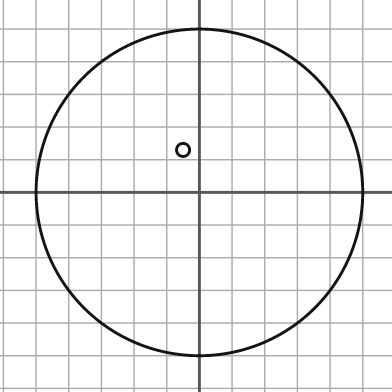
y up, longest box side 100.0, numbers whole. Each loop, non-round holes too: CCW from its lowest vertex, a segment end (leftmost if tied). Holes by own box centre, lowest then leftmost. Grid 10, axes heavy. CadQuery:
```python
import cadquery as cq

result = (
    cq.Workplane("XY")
    .moveTo(0.0, 0.0)
    .circle(50.0)
    .moveTo(-5.0, 13.0)
    .circle(2.0)
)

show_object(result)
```